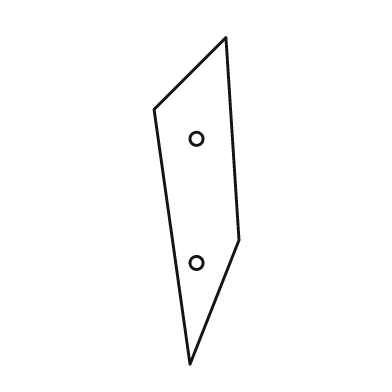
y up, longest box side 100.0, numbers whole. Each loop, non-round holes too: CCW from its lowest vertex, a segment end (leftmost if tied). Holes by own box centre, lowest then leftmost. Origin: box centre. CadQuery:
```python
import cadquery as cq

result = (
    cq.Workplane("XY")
    .moveTo(-2.0, -50.0)
    .lineTo(13.0, -12.0)
    .lineTo(9.0, 50.0)
    .lineTo(-13.0, 28.0)
    .close()
    .moveTo(0.0, -19.0)
    .circle(2.0)
    .moveTo(0.0, 19.0)
    .circle(2.0)
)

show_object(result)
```